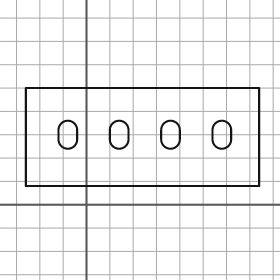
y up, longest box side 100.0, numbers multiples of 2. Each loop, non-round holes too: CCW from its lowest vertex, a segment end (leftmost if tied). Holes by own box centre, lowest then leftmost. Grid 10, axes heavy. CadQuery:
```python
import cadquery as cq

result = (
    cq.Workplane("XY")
    .moveTo(-26.0, 8.0)
    .lineTo(74.0, 8.0)
    .lineTo(74.0, 50.0)
    .lineTo(-26.0, 50.0)
    .close()
    .moveTo(-12.0, 28.0)
    .threePointArc((-8.0, 24.0), (-4.0, 28.0))
    .lineTo(-4.0, 32.0)
    .threePointArc((-8.0, 36.0), (-12.0, 32.0))
    .close()
    .moveTo(10.0, 28.0)
    .threePointArc((14.0, 24.0), (18.0, 28.0))
    .lineTo(18.0, 32.0)
    .threePointArc((14.0, 36.0), (10.0, 32.0))
    .close()
    .moveTo(32.0, 28.0)
    .threePointArc((36.0, 24.0), (40.0, 28.0))
    .lineTo(40.0, 32.0)
    .threePointArc((36.0, 36.0), (32.0, 32.0))
    .close()
    .moveTo(54.0, 28.0)
    .threePointArc((58.0, 24.0), (62.0, 28.0))
    .lineTo(62.0, 32.0)
    .threePointArc((58.0, 36.0), (54.0, 32.0))
    .close()
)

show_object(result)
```